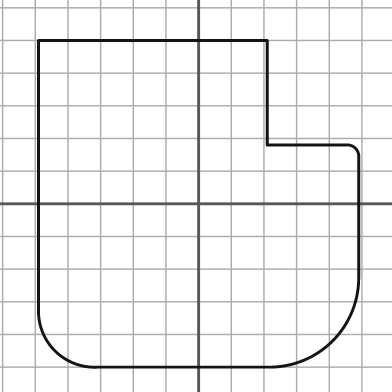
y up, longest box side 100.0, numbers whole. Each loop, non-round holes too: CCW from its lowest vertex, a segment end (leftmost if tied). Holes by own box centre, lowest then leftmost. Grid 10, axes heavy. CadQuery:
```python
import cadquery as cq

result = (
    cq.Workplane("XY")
    .moveTo(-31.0, -50.0)
    .lineTo(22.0, -50.0)
    .threePointArc((41.0, -42.0), (49.0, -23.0))
    .lineTo(49.0, 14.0)
    .threePointArc((48.0, 17.0), (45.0, 18.0))
    .lineTo(21.0, 18.0)
    .lineTo(21.0, 50.0)
    .lineTo(-49.0, 50.0)
    .lineTo(-49.0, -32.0)
    .threePointArc((-44.0, -45.0), (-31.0, -50.0))
    .close()
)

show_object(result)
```